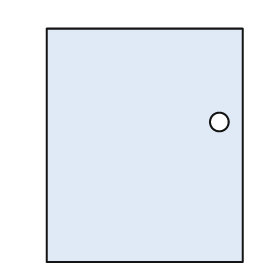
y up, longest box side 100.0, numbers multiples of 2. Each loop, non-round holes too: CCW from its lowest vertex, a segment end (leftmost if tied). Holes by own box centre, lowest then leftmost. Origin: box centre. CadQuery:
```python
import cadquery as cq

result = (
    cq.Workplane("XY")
    .moveTo(-42.0, -50.0)
    .lineTo(42.0, -50.0)
    .lineTo(42.0, 50.0)
    .lineTo(-42.0, 50.0)
    .close()
    .moveTo(32.0, 10.0)
    .circle(4.0)
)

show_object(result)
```